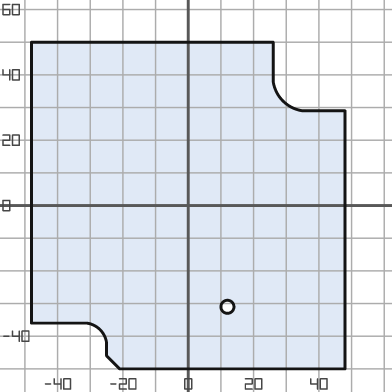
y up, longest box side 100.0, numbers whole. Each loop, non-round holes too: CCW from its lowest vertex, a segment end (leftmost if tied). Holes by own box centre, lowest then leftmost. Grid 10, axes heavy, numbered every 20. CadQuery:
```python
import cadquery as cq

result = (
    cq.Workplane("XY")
    .moveTo(-21.0, -50.0)
    .lineTo(48.0, -50.0)
    .lineTo(48.0, 29.0)
    .lineTo(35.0, 29.0)
    .threePointArc((29.0, 32.0), (26.0, 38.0))
    .lineTo(26.0, 50.0)
    .lineTo(-48.0, 50.0)
    .lineTo(-48.0, -36.0)
    .lineTo(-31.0, -36.0)
    .threePointArc((-27.0, -38.0), (-25.0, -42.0))
    .lineTo(-25.0, -46.0)
    .close()
    .moveTo(12.0, -31.0)
    .circle(2.0)
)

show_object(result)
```